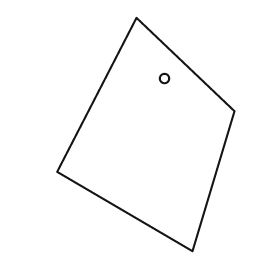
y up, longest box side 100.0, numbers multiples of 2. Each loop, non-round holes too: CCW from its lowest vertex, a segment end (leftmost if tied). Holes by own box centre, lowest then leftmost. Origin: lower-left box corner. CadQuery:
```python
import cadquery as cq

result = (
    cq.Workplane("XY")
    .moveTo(58.0, 0.0)
    .lineTo(76.0, 60.0)
    .lineTo(34.0, 100.0)
    .lineTo(0.0, 34.0)
    .close()
    .moveTo(46.0, 74.0)
    .circle(2.0)
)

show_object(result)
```